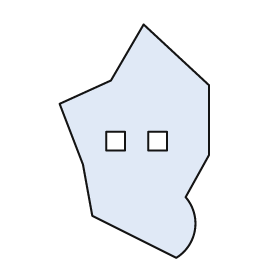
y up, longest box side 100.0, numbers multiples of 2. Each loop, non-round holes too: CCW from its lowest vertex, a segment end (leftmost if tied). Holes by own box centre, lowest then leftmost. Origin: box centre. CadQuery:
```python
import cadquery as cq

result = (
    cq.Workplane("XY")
    .moveTo(18.0, -50.0)
    .threePointArc((26.0, -38.0), (22.0, -24.0))
    .lineTo(32.0, -6.0)
    .lineTo(32.0, 24.0)
    .lineTo(4.0, 50.0)
    .lineTo(-10.0, 26.0)
    .lineTo(-32.0, 16.0)
    .lineTo(-22.0, -10.0)
    .lineTo(-18.0, -32.0)
    .close()
    .moveTo(-12.0, -4.0)
    .lineTo(-4.0, -4.0)
    .lineTo(-4.0, 4.0)
    .lineTo(-12.0, 4.0)
    .close()
    .moveTo(6.0, -4.0)
    .lineTo(14.0, -4.0)
    .lineTo(14.0, 4.0)
    .lineTo(6.0, 4.0)
    .close()
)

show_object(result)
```